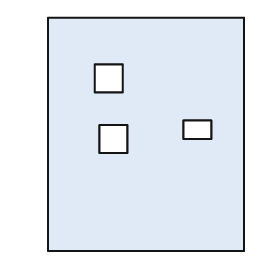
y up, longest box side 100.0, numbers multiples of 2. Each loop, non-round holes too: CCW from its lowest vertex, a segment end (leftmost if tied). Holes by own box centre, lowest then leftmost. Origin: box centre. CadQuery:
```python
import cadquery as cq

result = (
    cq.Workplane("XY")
    .moveTo(-42.0, -50.0)
    .lineTo(42.0, -50.0)
    .lineTo(42.0, 50.0)
    .lineTo(-42.0, 50.0)
    .close()
    .moveTo(-20.0, -8.0)
    .lineTo(-8.0, -8.0)
    .lineTo(-8.0, 4.0)
    .lineTo(-20.0, 4.0)
    .close()
    .moveTo(16.0, -2.0)
    .lineTo(28.0, -2.0)
    .lineTo(28.0, 6.0)
    .lineTo(16.0, 6.0)
    .close()
    .moveTo(-22.0, 18.0)
    .lineTo(-10.0, 18.0)
    .lineTo(-10.0, 30.0)
    .lineTo(-22.0, 30.0)
    .close()
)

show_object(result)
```